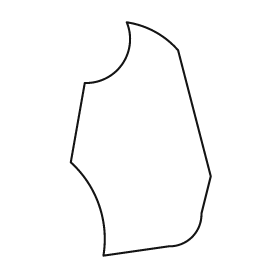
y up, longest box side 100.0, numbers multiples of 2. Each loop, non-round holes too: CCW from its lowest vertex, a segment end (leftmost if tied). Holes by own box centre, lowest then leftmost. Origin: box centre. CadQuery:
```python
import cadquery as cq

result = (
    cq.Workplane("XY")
    .moveTo(-16.0, -50.0)
    .lineTo(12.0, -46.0)
    .threePointArc((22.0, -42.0), (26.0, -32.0))
    .lineTo(30.0, -16.0)
    .lineTo(16.0, 38.0)
    .threePointArc((6.0, 46.0), (-6.0, 50.0))
    .threePointArc((-8.0, 32.0), (-24.0, 24.0))
    .lineTo(-30.0, -10.0)
    .threePointArc((-18.0, -28.0), (-16.0, -50.0))
    .close()
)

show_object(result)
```